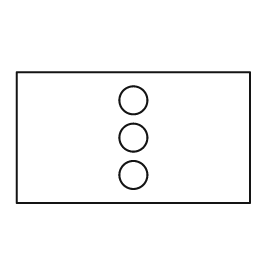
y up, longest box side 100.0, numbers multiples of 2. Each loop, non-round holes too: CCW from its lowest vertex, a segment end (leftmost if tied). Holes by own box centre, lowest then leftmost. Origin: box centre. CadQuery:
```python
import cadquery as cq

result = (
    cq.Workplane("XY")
    .moveTo(-50.0, -28.0)
    .lineTo(50.0, -28.0)
    .lineTo(50.0, 28.0)
    .lineTo(-50.0, 28.0)
    .close()
    .moveTo(0.0, -16.0)
    .circle(6.0)
    .moveTo(0.0, 0.0)
    .circle(6.0)
    .moveTo(0.0, 16.0)
    .circle(6.0)
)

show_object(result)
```